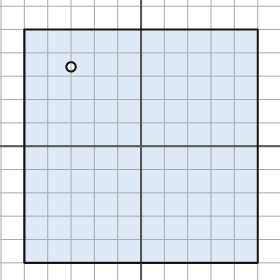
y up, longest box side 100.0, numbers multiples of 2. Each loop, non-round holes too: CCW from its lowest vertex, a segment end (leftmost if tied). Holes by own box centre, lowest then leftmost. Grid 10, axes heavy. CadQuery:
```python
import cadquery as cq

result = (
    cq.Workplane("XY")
    .moveTo(-50.0, -50.0)
    .lineTo(50.0, -50.0)
    .lineTo(50.0, 50.0)
    .lineTo(-50.0, 50.0)
    .close()
    .moveTo(-30.0, 34.0)
    .circle(2.0)
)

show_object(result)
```